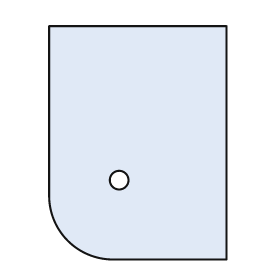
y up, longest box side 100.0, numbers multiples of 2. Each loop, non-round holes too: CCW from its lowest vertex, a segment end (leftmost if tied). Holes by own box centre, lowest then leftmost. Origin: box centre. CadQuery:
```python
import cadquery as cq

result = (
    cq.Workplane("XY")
    .moveTo(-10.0, -50.0)
    .lineTo(38.0, -50.0)
    .lineTo(38.0, 50.0)
    .lineTo(-38.0, 50.0)
    .lineTo(-38.0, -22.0)
    .threePointArc((-30.0, -42.0), (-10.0, -50.0))
    .close()
    .moveTo(-8.0, -16.0)
    .circle(4.0)
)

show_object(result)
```